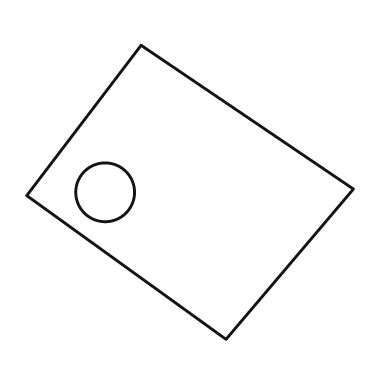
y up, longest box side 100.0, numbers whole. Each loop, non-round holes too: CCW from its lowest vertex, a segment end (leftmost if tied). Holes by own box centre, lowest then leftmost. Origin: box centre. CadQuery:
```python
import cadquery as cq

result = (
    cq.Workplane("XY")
    .moveTo(11.0, -45.0)
    .lineTo(50.0, 1.0)
    .lineTo(-15.0, 45.0)
    .lineTo(-50.0, -1.0)
    .close()
    .moveTo(-26.0, 0.0)
    .circle(9.0)
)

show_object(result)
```